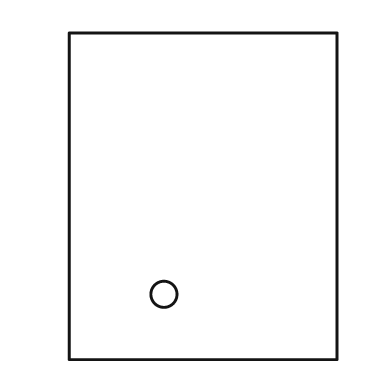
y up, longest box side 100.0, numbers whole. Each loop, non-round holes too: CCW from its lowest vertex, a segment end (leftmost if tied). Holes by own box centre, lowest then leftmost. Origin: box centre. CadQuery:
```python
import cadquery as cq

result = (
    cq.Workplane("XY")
    .moveTo(-41.0, -50.0)
    .lineTo(41.0, -50.0)
    .lineTo(41.0, 50.0)
    .lineTo(-41.0, 50.0)
    .close()
    .moveTo(-12.0, -30.0)
    .circle(4.0)
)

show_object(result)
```